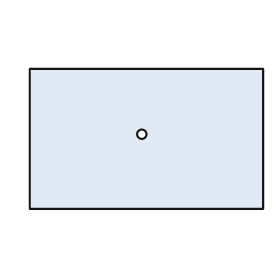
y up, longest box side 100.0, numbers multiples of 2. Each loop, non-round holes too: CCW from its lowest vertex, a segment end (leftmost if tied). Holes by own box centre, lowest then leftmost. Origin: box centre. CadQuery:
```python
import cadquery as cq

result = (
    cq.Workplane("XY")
    .moveTo(-50.0, -30.0)
    .lineTo(50.0, -30.0)
    .lineTo(50.0, 30.0)
    .lineTo(-50.0, 30.0)
    .close()
    .moveTo(-2.0, 2.0)
    .circle(2.0)
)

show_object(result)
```